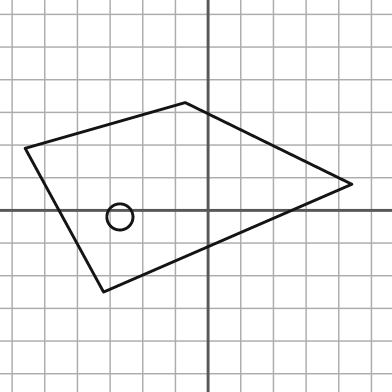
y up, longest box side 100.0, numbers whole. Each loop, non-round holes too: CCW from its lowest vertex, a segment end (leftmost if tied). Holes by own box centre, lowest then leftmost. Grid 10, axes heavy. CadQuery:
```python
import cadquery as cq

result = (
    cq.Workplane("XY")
    .moveTo(-32.0, -25.0)
    .lineTo(44.0, 8.0)
    .lineTo(-7.0, 33.0)
    .lineTo(-56.0, 19.0)
    .close()
    .moveTo(-27.0, -2.0)
    .circle(4.0)
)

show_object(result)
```